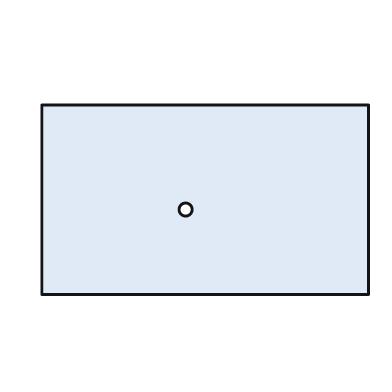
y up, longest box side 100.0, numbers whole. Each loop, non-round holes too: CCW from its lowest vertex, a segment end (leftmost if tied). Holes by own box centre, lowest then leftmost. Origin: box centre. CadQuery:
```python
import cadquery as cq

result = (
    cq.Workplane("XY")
    .moveTo(-50.0, -29.0)
    .lineTo(50.0, -29.0)
    .lineTo(50.0, 29.0)
    .lineTo(-50.0, 29.0)
    .close()
    .moveTo(-6.0, -3.0)
    .circle(2.0)
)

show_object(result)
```